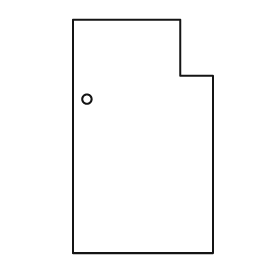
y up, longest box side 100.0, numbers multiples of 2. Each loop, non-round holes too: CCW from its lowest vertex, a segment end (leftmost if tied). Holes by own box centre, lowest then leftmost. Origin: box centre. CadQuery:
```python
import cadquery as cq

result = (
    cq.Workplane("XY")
    .moveTo(-30.0, -50.0)
    .lineTo(30.0, -50.0)
    .lineTo(30.0, 26.0)
    .lineTo(16.0, 26.0)
    .lineTo(16.0, 50.0)
    .lineTo(-30.0, 50.0)
    .close()
    .moveTo(-24.0, 16.0)
    .circle(2.0)
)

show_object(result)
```